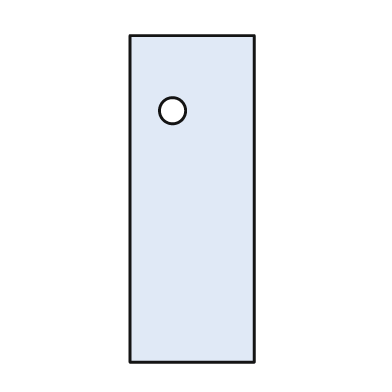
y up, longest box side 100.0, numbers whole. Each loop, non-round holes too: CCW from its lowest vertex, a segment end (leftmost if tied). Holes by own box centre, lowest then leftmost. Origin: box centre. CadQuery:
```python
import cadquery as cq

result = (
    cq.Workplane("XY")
    .moveTo(-19.0, -50.0)
    .lineTo(19.0, -50.0)
    .lineTo(19.0, 50.0)
    .lineTo(-19.0, 50.0)
    .close()
    .moveTo(-6.0, 27.0)
    .circle(4.0)
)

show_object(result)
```